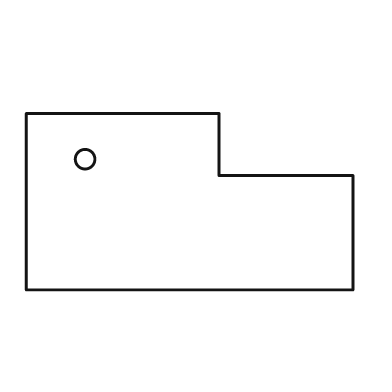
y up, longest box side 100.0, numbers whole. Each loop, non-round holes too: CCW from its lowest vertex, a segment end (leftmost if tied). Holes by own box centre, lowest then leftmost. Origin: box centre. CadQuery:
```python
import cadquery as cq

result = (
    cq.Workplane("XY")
    .moveTo(-50.0, -27.0)
    .lineTo(50.0, -27.0)
    .lineTo(50.0, 8.0)
    .lineTo(9.0, 8.0)
    .lineTo(9.0, 27.0)
    .lineTo(-50.0, 27.0)
    .close()
    .moveTo(-32.0, 13.0)
    .circle(3.0)
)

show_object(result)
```